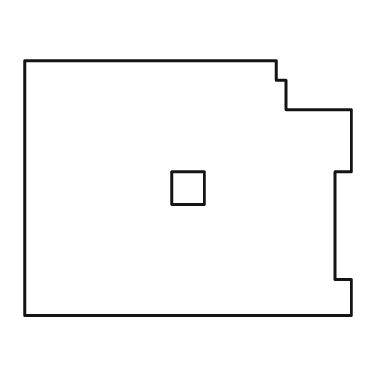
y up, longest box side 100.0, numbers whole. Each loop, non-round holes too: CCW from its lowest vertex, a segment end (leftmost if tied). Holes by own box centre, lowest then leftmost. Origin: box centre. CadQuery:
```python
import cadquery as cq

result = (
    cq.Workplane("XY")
    .moveTo(-50.0, -39.0)
    .lineTo(50.0, -39.0)
    .lineTo(50.0, -28.0)
    .lineTo(45.0, -28.0)
    .lineTo(45.0, 5.0)
    .lineTo(50.0, 5.0)
    .lineTo(50.0, 24.0)
    .lineTo(30.0, 24.0)
    .lineTo(30.0, 33.0)
    .lineTo(27.0, 33.0)
    .lineTo(27.0, 39.0)
    .lineTo(-50.0, 39.0)
    .close()
    .moveTo(-5.0, -5.0)
    .lineTo(5.0, -5.0)
    .lineTo(5.0, 5.0)
    .lineTo(-5.0, 5.0)
    .close()
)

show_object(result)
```